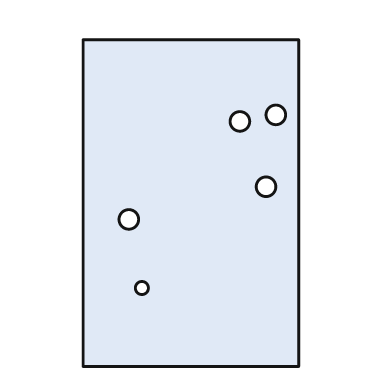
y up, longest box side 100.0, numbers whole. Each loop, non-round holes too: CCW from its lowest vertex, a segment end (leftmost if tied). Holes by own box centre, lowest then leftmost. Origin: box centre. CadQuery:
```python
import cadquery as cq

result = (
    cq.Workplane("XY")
    .moveTo(-33.0, -50.0)
    .lineTo(33.0, -50.0)
    .lineTo(33.0, 50.0)
    .lineTo(-33.0, 50.0)
    .close()
    .moveTo(-15.0, -26.0)
    .circle(2.0)
    .moveTo(-19.0, -5.0)
    .circle(3.0)
    .moveTo(23.0, 5.0)
    .circle(3.0)
    .moveTo(15.0, 25.0)
    .circle(3.0)
    .moveTo(26.0, 27.0)
    .circle(3.0)
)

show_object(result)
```